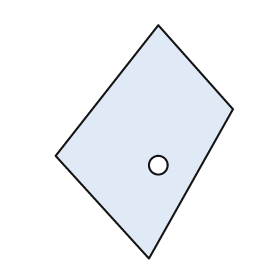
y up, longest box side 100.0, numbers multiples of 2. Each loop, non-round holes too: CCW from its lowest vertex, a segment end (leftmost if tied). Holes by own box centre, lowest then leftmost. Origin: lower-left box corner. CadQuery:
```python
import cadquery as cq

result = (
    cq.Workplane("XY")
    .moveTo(40.0, 0.0)
    .lineTo(76.0, 64.0)
    .lineTo(44.0, 100.0)
    .lineTo(0.0, 44.0)
    .close()
    .moveTo(44.0, 40.0)
    .circle(4.0)
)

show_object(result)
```